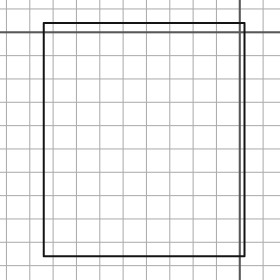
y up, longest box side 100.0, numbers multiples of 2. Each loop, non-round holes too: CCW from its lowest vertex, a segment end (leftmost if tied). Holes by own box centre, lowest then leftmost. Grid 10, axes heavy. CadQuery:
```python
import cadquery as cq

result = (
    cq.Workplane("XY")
    .moveTo(-84.0, -96.0)
    .lineTo(2.0, -96.0)
    .lineTo(2.0, 4.0)
    .lineTo(-84.0, 4.0)
    .close()
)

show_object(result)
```